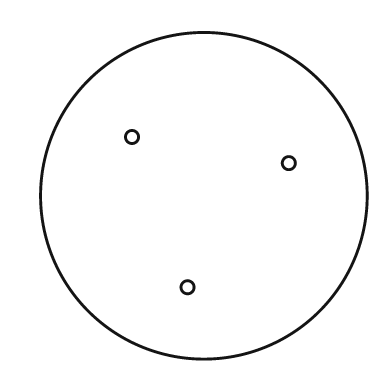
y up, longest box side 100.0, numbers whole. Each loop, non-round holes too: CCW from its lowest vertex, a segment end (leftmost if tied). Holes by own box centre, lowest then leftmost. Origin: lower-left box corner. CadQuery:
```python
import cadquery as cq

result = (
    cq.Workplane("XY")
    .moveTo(50.0, 50.0)
    .circle(50.0)
    .moveTo(45.0, 22.0)
    .circle(2.0)
    .moveTo(76.0, 60.0)
    .circle(2.0)
    .moveTo(28.0, 68.0)
    .circle(2.0)
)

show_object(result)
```